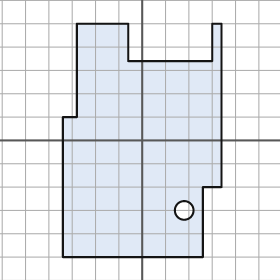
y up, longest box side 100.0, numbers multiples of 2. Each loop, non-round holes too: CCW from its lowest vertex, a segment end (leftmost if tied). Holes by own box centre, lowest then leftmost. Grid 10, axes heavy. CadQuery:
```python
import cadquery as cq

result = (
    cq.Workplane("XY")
    .moveTo(-34.0, -50.0)
    .lineTo(26.0, -50.0)
    .lineTo(26.0, -20.0)
    .lineTo(34.0, -20.0)
    .lineTo(34.0, 50.0)
    .lineTo(30.0, 50.0)
    .lineTo(30.0, 34.0)
    .lineTo(-6.0, 34.0)
    .lineTo(-6.0, 50.0)
    .lineTo(-28.0, 50.0)
    .lineTo(-28.0, 10.0)
    .lineTo(-34.0, 10.0)
    .close()
    .moveTo(18.0, -30.0)
    .circle(4.0)
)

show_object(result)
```